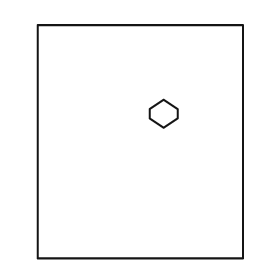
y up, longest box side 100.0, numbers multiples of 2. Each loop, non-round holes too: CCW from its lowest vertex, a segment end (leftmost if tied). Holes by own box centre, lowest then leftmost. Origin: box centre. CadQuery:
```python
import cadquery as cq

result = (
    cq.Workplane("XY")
    .moveTo(-44.0, -50.0)
    .lineTo(44.0, -50.0)
    .lineTo(44.0, 50.0)
    .lineTo(-44.0, 50.0)
    .close()
    .moveTo(10.0, 6.0)
    .lineTo(16.0, 10.0)
    .lineTo(16.0, 14.0)
    .lineTo(10.0, 18.0)
    .lineTo(4.0, 14.0)
    .lineTo(4.0, 10.0)
    .close()
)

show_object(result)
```